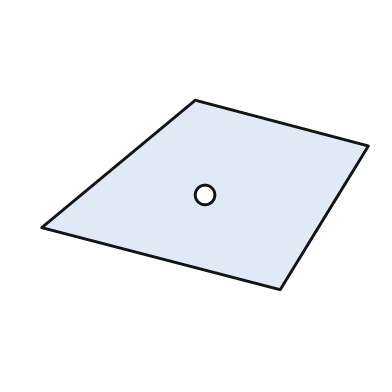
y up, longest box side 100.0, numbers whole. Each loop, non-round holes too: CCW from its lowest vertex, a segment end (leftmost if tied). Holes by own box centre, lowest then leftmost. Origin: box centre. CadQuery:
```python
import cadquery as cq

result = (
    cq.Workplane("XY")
    .moveTo(23.0, -29.0)
    .lineTo(50.0, 15.0)
    .lineTo(-3.0, 29.0)
    .lineTo(-50.0, -10.0)
    .close()
    .moveTo(0.0, 0.0)
    .circle(3.0)
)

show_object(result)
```